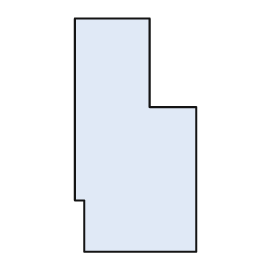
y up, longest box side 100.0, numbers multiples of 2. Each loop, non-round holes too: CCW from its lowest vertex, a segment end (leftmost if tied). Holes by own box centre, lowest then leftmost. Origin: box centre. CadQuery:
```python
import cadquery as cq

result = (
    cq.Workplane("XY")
    .moveTo(-22.0, -50.0)
    .lineTo(26.0, -50.0)
    .lineTo(26.0, 12.0)
    .lineTo(6.0, 12.0)
    .lineTo(6.0, 50.0)
    .lineTo(-26.0, 50.0)
    .lineTo(-26.0, -28.0)
    .lineTo(-22.0, -28.0)
    .close()
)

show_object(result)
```